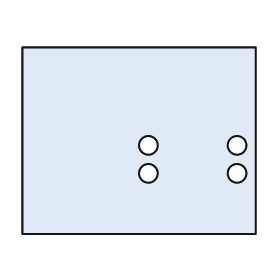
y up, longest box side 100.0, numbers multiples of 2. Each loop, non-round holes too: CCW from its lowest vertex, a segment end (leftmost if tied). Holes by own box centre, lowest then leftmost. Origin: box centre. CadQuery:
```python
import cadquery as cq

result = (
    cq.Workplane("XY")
    .moveTo(-50.0, -40.0)
    .lineTo(50.0, -40.0)
    .lineTo(50.0, 40.0)
    .lineTo(-50.0, 40.0)
    .close()
    .moveTo(4.0, -14.0)
    .circle(4.0)
    .moveTo(42.0, -14.0)
    .circle(4.0)
    .moveTo(4.0, -2.0)
    .circle(4.0)
    .moveTo(42.0, -2.0)
    .circle(4.0)
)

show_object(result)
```